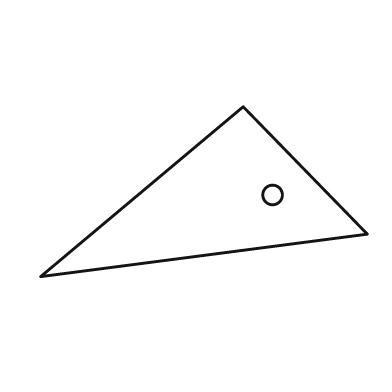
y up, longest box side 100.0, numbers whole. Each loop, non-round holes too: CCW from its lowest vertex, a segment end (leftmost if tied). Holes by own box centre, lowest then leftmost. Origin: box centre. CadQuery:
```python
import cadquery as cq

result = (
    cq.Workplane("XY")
    .moveTo(-50.0, -26.0)
    .lineTo(50.0, -13.0)
    .lineTo(12.0, 26.0)
    .close()
    .moveTo(21.0, -1.0)
    .circle(3.0)
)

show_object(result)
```